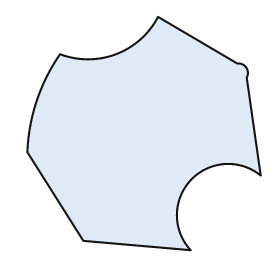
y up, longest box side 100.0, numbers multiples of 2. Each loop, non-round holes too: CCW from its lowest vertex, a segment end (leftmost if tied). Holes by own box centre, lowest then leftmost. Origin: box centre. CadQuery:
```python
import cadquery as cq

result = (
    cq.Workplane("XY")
    .moveTo(20.0, -50.0)
    .threePointArc((20.0, -20.0), (50.0, -18.0))
    .lineTo(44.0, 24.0)
    .threePointArc((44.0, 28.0), (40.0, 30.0))
    .lineTo(6.0, 50.0)
    .threePointArc((-12.0, 34.0), (-36.0, 34.0))
    .threePointArc((-46.0, 14.0), (-50.0, -8.0))
    .lineTo(-26.0, -46.0)
    .close()
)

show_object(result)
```